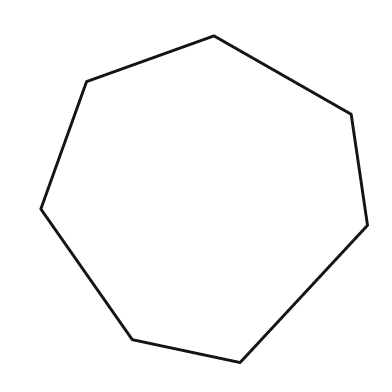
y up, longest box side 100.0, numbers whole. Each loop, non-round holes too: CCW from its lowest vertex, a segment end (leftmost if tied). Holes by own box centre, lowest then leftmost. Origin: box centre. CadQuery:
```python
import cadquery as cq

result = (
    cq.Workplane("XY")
    .moveTo(11.0, -50.0)
    .lineTo(50.0, -8.0)
    .lineTo(45.0, 26.0)
    .lineTo(3.0, 50.0)
    .lineTo(-36.0, 36.0)
    .lineTo(-50.0, -3.0)
    .lineTo(-22.0, -43.0)
    .close()
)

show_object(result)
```